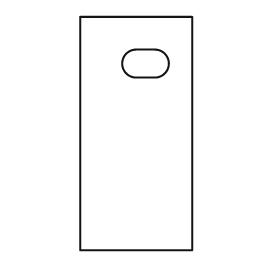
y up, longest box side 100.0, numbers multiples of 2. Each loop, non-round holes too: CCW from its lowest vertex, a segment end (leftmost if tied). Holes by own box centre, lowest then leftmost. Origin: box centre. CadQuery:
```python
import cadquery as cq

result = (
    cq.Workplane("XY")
    .moveTo(-24.0, -50.0)
    .lineTo(24.0, -50.0)
    .lineTo(24.0, 50.0)
    .lineTo(-24.0, 50.0)
    .close()
    .moveTo(0.0, 24.0)
    .lineTo(8.0, 24.0)
    .threePointArc((14.0, 30.0), (8.0, 36.0))
    .lineTo(0.0, 36.0)
    .threePointArc((-6.0, 30.0), (0.0, 24.0))
    .close()
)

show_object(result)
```